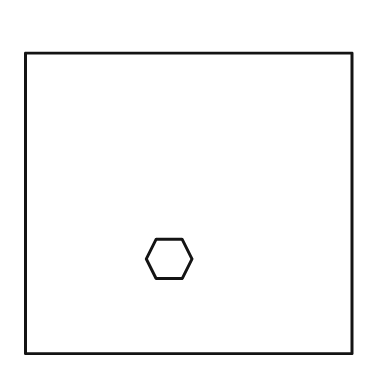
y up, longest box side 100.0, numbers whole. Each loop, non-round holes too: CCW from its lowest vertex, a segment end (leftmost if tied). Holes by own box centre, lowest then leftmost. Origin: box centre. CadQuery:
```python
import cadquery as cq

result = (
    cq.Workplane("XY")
    .moveTo(-50.0, -46.0)
    .lineTo(50.0, -46.0)
    .lineTo(50.0, 46.0)
    .lineTo(-50.0, 46.0)
    .close()
    .moveTo(-10.0, -23.0)
    .lineTo(-2.0, -23.0)
    .lineTo(1.0, -17.0)
    .lineTo(-2.0, -11.0)
    .lineTo(-10.0, -11.0)
    .lineTo(-13.0, -17.0)
    .close()
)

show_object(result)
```